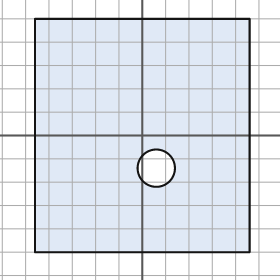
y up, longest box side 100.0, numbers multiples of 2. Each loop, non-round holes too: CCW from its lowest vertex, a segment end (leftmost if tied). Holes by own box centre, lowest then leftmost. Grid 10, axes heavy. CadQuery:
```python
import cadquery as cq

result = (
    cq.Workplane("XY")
    .moveTo(-46.0, -50.0)
    .lineTo(46.0, -50.0)
    .lineTo(46.0, 50.0)
    .lineTo(-46.0, 50.0)
    .close()
    .moveTo(6.0, -14.0)
    .circle(8.0)
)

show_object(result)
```